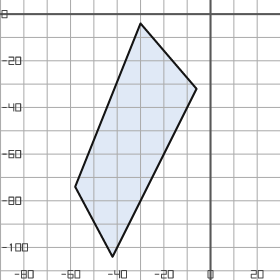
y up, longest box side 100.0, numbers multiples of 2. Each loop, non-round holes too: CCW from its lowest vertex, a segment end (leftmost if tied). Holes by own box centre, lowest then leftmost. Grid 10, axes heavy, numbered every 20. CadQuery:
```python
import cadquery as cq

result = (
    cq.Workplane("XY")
    .moveTo(-42.0, -104.0)
    .lineTo(-6.0, -32.0)
    .lineTo(-30.0, -4.0)
    .lineTo(-58.0, -74.0)
    .close()
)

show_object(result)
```